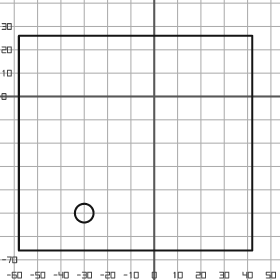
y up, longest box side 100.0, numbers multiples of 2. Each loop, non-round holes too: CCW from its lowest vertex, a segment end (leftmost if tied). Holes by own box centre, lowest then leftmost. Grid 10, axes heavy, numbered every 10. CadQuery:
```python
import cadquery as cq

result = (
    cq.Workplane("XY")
    .moveTo(-58.0, -66.0)
    .lineTo(42.0, -66.0)
    .lineTo(42.0, 26.0)
    .lineTo(-58.0, 26.0)
    .close()
    .moveTo(-30.0, -50.0)
    .circle(4.0)
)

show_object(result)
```